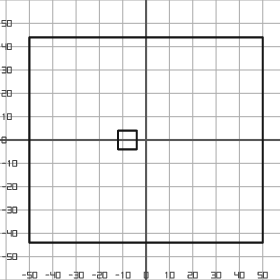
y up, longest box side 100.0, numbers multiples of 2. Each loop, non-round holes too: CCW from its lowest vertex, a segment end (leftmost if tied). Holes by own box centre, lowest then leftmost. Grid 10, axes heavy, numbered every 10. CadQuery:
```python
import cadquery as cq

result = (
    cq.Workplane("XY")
    .moveTo(-50.0, -44.0)
    .lineTo(50.0, -44.0)
    .lineTo(50.0, 44.0)
    .lineTo(-50.0, 44.0)
    .close()
    .moveTo(-12.0, -4.0)
    .lineTo(-4.0, -4.0)
    .lineTo(-4.0, 4.0)
    .lineTo(-12.0, 4.0)
    .close()
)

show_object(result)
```